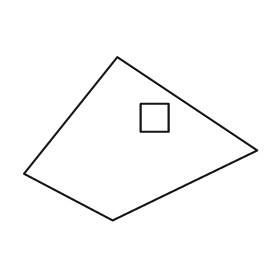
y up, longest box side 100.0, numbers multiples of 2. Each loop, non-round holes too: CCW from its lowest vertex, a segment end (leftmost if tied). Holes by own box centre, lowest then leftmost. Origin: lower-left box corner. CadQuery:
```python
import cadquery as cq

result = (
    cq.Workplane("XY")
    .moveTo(38.0, 0.0)
    .lineTo(100.0, 30.0)
    .lineTo(40.0, 70.0)
    .lineTo(0.0, 20.0)
    .close()
    .moveTo(50.0, 38.0)
    .lineTo(62.0, 38.0)
    .lineTo(62.0, 50.0)
    .lineTo(50.0, 50.0)
    .close()
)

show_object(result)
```